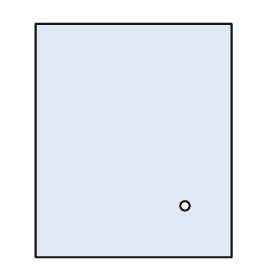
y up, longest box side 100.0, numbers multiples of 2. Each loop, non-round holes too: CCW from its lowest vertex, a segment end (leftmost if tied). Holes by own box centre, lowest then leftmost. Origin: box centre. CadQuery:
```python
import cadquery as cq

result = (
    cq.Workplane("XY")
    .moveTo(-42.0, -50.0)
    .lineTo(42.0, -50.0)
    .lineTo(42.0, 50.0)
    .lineTo(-42.0, 50.0)
    .close()
    .moveTo(22.0, -28.0)
    .circle(2.0)
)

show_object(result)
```